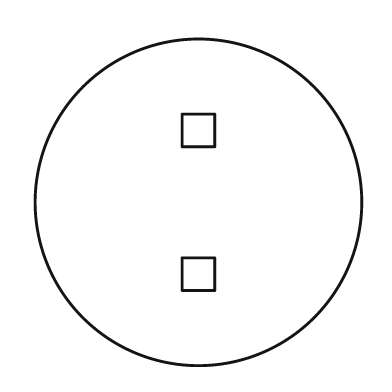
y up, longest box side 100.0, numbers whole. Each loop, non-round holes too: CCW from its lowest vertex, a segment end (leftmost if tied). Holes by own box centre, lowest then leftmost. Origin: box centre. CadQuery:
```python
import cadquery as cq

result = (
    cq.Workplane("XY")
    .moveTo(0.0, 0.0)
    .circle(50.0)
    .moveTo(-5.0, -27.0)
    .lineTo(5.0, -27.0)
    .lineTo(5.0, -17.0)
    .lineTo(-5.0, -17.0)
    .close()
    .moveTo(-5.0, 17.0)
    .lineTo(5.0, 17.0)
    .lineTo(5.0, 27.0)
    .lineTo(-5.0, 27.0)
    .close()
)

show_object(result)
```